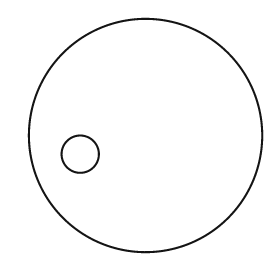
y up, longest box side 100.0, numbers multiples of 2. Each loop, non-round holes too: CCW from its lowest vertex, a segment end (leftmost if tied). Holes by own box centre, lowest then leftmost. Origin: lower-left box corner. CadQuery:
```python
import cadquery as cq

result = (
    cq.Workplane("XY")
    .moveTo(50.0, 50.0)
    .circle(50.0)
    .moveTo(22.0, 42.0)
    .circle(8.0)
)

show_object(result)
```